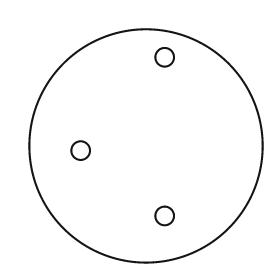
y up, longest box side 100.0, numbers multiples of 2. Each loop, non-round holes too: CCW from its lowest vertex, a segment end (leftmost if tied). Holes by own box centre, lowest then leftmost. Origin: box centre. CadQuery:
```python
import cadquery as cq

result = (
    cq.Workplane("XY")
    .moveTo(0.0, 0.0)
    .circle(50.0)
    .moveTo(8.0, -30.0)
    .circle(4.0)
    .moveTo(-28.0, -2.0)
    .circle(4.0)
    .moveTo(8.0, 38.0)
    .circle(4.0)
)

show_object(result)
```